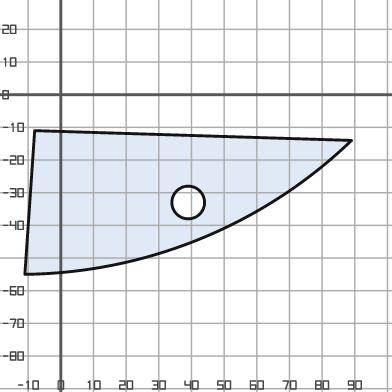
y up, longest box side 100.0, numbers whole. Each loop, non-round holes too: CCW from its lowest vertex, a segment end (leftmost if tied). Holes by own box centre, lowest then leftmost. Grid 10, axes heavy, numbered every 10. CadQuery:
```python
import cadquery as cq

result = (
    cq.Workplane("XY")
    .moveTo(-11.0, -55.0)
    .threePointArc((43.0, -44.0), (89.0, -14.0))
    .lineTo(-8.0, -11.0)
    .close()
    .moveTo(39.0, -33.0)
    .circle(5.0)
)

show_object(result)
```